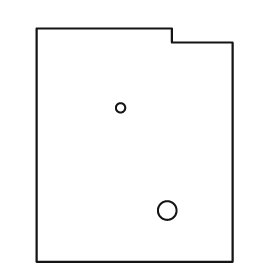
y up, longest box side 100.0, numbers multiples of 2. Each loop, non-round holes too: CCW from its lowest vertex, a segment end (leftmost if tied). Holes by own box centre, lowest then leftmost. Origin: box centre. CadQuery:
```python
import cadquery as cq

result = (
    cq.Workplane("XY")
    .moveTo(-42.0, -50.0)
    .lineTo(42.0, -50.0)
    .lineTo(42.0, 44.0)
    .lineTo(16.0, 44.0)
    .lineTo(16.0, 50.0)
    .lineTo(-42.0, 50.0)
    .close()
    .moveTo(14.0, -28.0)
    .circle(4.0)
    .moveTo(-6.0, 16.0)
    .circle(2.0)
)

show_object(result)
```